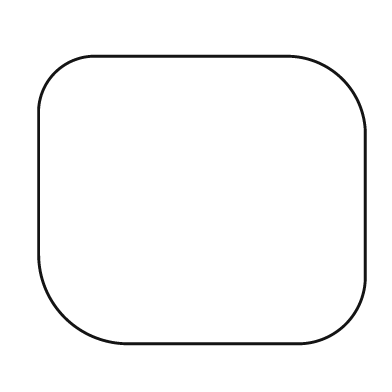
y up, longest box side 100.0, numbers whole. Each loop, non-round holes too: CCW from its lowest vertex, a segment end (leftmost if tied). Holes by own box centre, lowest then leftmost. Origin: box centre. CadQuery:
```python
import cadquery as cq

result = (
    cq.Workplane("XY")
    .moveTo(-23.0, -44.0)
    .lineTo(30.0, -44.0)
    .threePointArc((44.0, -38.0), (50.0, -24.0))
    .lineTo(50.0, 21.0)
    .threePointArc((43.0, 37.0), (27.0, 44.0))
    .lineTo(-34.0, 44.0)
    .threePointArc((-45.0, 39.0), (-50.0, 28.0))
    .lineTo(-50.0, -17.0)
    .threePointArc((-42.0, -36.0), (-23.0, -44.0))
    .close()
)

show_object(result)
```